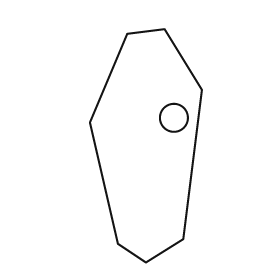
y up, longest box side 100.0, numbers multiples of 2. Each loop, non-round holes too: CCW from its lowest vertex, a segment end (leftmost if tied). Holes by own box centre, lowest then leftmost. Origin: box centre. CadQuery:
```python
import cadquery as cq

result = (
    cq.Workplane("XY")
    .moveTo(0.0, -50.0)
    .lineTo(16.0, -40.0)
    .lineTo(24.0, 24.0)
    .lineTo(8.0, 50.0)
    .lineTo(-8.0, 48.0)
    .lineTo(-24.0, 10.0)
    .lineTo(-12.0, -42.0)
    .close()
    .moveTo(12.0, 12.0)
    .circle(6.0)
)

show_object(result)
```